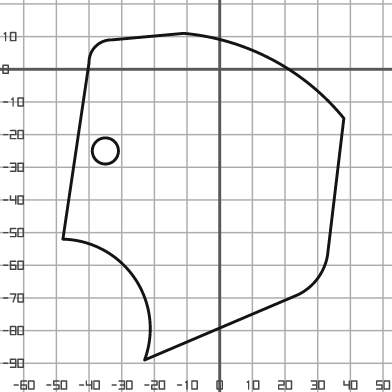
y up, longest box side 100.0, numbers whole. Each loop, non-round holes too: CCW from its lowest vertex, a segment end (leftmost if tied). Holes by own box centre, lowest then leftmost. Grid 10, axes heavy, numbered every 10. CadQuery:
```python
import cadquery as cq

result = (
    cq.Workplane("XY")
    .moveTo(-23.0, -89.0)
    .lineTo(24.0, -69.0)
    .threePointArc((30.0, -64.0), (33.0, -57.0))
    .lineTo(38.0, -15.0)
    .threePointArc((16.0, 3.0), (-11.0, 11.0))
    .lineTo(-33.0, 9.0)
    .threePointArc((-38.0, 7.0), (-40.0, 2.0))
    .lineTo(-48.0, -52.0)
    .threePointArc((-26.0, -64.0), (-23.0, -89.0))
    .close()
    .moveTo(-35.0, -25.0)
    .circle(4.0)
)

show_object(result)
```